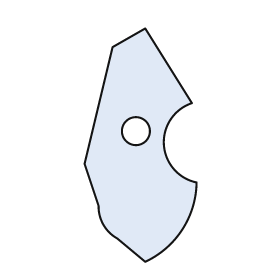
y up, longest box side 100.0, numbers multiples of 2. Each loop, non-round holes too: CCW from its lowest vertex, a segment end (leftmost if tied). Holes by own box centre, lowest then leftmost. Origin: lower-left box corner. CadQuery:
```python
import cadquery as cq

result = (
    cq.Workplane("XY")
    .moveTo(26.0, 0.0)
    .threePointArc((42.0, 14.0), (48.0, 34.0))
    .threePointArc((34.0, 50.0), (46.0, 68.0))
    .lineTo(26.0, 100.0)
    .lineTo(12.0, 92.0)
    .lineTo(0.0, 42.0)
    .lineTo(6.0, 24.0)
    .threePointArc((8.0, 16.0), (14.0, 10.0))
    .close()
    .moveTo(22.0, 56.0)
    .circle(6.0)
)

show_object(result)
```